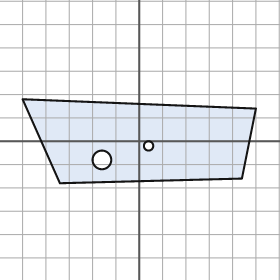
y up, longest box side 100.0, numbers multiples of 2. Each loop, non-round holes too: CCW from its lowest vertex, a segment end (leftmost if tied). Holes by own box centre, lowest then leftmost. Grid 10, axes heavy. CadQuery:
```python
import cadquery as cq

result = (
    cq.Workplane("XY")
    .moveTo(-34.0, -18.0)
    .lineTo(44.0, -16.0)
    .lineTo(50.0, 14.0)
    .lineTo(-50.0, 18.0)
    .close()
    .moveTo(-16.0, -8.0)
    .circle(4.0)
    .moveTo(4.0, -2.0)
    .circle(2.0)
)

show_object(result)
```